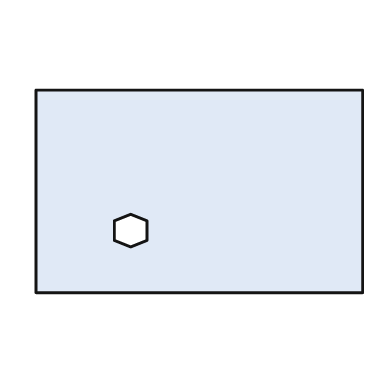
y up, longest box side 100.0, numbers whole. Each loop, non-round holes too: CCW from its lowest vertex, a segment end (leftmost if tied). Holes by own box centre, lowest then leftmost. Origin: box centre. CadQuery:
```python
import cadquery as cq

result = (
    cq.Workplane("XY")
    .moveTo(-50.0, -31.0)
    .lineTo(50.0, -31.0)
    .lineTo(50.0, 31.0)
    .lineTo(-50.0, 31.0)
    .close()
    .moveTo(-21.0, -17.0)
    .lineTo(-16.0, -15.0)
    .lineTo(-16.0, -9.0)
    .lineTo(-21.0, -7.0)
    .lineTo(-26.0, -9.0)
    .lineTo(-26.0, -15.0)
    .close()
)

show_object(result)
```